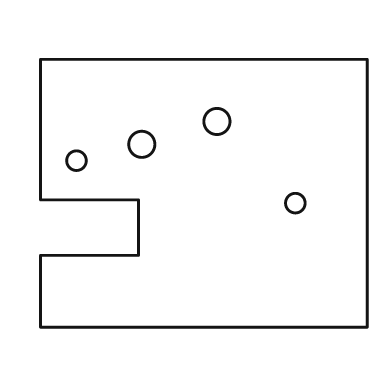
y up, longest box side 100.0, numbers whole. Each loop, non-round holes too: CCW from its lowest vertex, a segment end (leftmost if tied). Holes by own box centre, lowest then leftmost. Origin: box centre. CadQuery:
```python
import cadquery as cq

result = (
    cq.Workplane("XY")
    .moveTo(-50.0, -41.0)
    .lineTo(50.0, -41.0)
    .lineTo(50.0, 41.0)
    .lineTo(-50.0, 41.0)
    .lineTo(-50.0, -2.0)
    .lineTo(-20.0, -2.0)
    .lineTo(-20.0, -19.0)
    .lineTo(-50.0, -19.0)
    .close()
    .moveTo(28.0, -3.0)
    .circle(3.0)
    .moveTo(-39.0, 10.0)
    .circle(3.0)
    .moveTo(-19.0, 15.0)
    .circle(4.0)
    .moveTo(4.0, 22.0)
    .circle(4.0)
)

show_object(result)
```